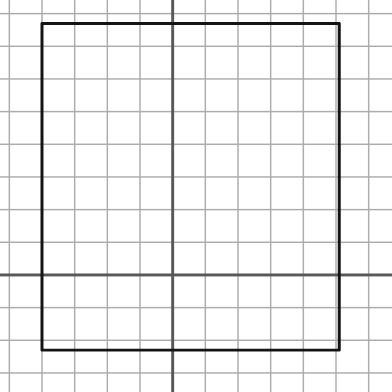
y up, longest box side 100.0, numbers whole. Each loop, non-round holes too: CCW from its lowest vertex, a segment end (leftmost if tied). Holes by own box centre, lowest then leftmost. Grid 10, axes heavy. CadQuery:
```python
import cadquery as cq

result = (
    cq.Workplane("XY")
    .moveTo(-40.0, -23.0)
    .lineTo(51.0, -23.0)
    .lineTo(51.0, 77.0)
    .lineTo(-40.0, 77.0)
    .close()
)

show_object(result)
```